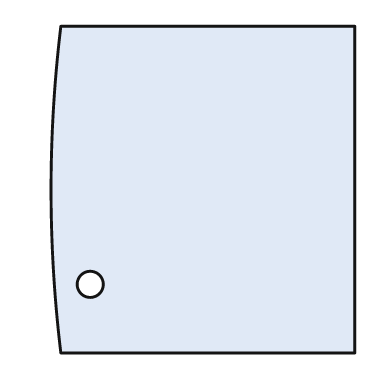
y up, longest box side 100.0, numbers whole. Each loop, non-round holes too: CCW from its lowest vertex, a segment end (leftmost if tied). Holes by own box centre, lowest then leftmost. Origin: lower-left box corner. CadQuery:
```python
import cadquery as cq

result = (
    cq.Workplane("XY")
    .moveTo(3.0, 0.0)
    .lineTo(93.0, 0.0)
    .lineTo(93.0, 100.0)
    .lineTo(3.0, 100.0)
    .threePointArc((0.0, 50.0), (3.0, 0.0))
    .close()
    .moveTo(12.0, 21.0)
    .circle(4.0)
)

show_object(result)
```